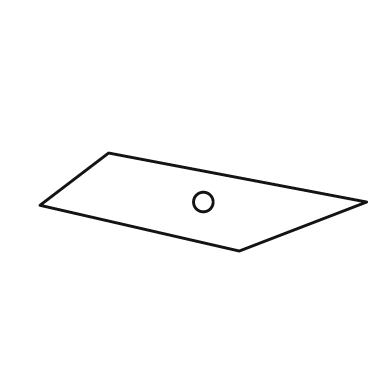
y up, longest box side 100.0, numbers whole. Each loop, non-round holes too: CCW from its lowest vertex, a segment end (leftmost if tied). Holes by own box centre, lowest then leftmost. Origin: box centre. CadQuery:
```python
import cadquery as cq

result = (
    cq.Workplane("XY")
    .moveTo(11.0, -15.0)
    .lineTo(50.0, 0.0)
    .lineTo(-29.0, 15.0)
    .lineTo(-50.0, -1.0)
    .close()
    .moveTo(0.0, 0.0)
    .circle(3.0)
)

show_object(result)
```